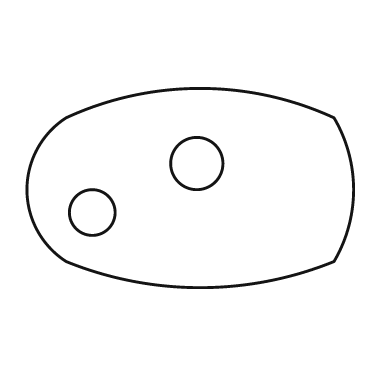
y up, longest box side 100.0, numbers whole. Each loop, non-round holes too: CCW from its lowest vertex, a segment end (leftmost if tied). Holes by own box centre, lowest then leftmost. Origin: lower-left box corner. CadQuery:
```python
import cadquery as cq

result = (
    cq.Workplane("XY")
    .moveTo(12.0, 8.0)
    .threePointArc((53.0, 0.0), (94.0, 8.0))
    .threePointArc((100.0, 30.0), (94.0, 52.0))
    .threePointArc((53.0, 61.0), (12.0, 52.0))
    .threePointArc((0.0, 30.0), (12.0, 8.0))
    .close()
    .moveTo(20.0, 23.0)
    .circle(7.0)
    .moveTo(52.0, 38.0)
    .circle(8.0)
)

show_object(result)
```